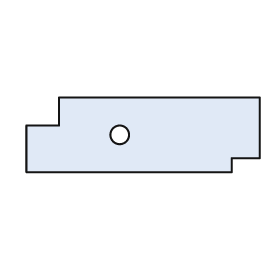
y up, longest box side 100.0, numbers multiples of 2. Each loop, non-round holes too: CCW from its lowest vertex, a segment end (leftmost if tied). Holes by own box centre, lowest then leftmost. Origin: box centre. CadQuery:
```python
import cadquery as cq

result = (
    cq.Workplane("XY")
    .moveTo(-50.0, -16.0)
    .lineTo(38.0, -16.0)
    .lineTo(38.0, -10.0)
    .lineTo(50.0, -10.0)
    .lineTo(50.0, 16.0)
    .lineTo(-36.0, 16.0)
    .lineTo(-36.0, 4.0)
    .lineTo(-50.0, 4.0)
    .close()
    .moveTo(-10.0, 0.0)
    .circle(4.0)
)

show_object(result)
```